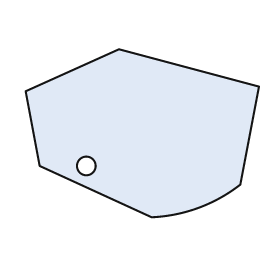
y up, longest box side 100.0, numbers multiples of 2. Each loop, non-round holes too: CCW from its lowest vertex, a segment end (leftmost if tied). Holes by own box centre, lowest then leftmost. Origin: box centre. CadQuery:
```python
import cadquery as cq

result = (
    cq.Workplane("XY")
    .moveTo(4.0, -36.0)
    .threePointArc((24.0, -32.0), (42.0, -22.0))
    .lineTo(50.0, 20.0)
    .lineTo(-10.0, 36.0)
    .lineTo(-50.0, 18.0)
    .lineTo(-44.0, -14.0)
    .close()
    .moveTo(-24.0, -14.0)
    .circle(4.0)
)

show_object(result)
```